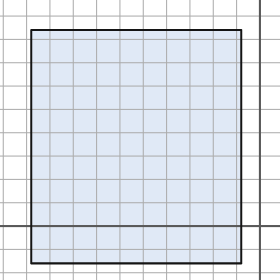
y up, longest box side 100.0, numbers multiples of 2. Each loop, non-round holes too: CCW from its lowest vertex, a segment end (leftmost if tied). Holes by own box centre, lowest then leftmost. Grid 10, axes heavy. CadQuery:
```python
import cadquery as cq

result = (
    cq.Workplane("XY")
    .moveTo(-98.0, -16.0)
    .lineTo(-8.0, -16.0)
    .lineTo(-8.0, 84.0)
    .lineTo(-98.0, 84.0)
    .close()
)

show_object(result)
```